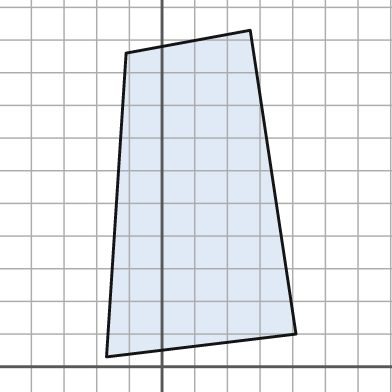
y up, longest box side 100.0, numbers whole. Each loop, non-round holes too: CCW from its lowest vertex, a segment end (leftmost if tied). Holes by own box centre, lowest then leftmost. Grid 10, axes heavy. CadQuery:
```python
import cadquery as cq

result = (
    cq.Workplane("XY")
    .moveTo(-17.0, 3.0)
    .lineTo(41.0, 10.0)
    .lineTo(27.0, 103.0)
    .lineTo(-11.0, 96.0)
    .close()
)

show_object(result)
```